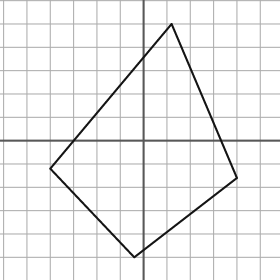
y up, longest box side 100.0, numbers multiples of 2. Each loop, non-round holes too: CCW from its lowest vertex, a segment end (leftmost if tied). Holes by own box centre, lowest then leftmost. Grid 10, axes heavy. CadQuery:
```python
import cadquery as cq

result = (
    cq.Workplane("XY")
    .moveTo(-4.0, -50.0)
    .lineTo(40.0, -16.0)
    .lineTo(12.0, 50.0)
    .lineTo(-40.0, -12.0)
    .close()
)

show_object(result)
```